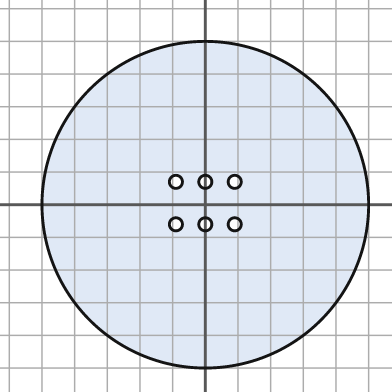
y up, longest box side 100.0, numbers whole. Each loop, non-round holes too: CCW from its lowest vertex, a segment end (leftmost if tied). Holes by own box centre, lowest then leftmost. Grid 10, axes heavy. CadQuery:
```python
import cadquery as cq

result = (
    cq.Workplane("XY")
    .moveTo(0.0, 0.0)
    .circle(50.0)
    .moveTo(-9.0, -6.0)
    .circle(2.0)
    .moveTo(0.0, -6.0)
    .circle(2.0)
    .moveTo(9.0, -6.0)
    .circle(2.0)
    .moveTo(-9.0, 7.0)
    .circle(2.0)
    .moveTo(0.0, 7.0)
    .circle(2.0)
    .moveTo(9.0, 7.0)
    .circle(2.0)
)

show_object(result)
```